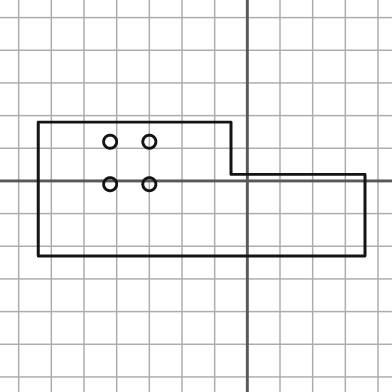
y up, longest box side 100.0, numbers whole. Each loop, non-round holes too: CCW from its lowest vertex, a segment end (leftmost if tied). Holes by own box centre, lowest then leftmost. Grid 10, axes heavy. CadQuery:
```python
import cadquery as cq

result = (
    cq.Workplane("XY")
    .moveTo(-64.0, -23.0)
    .lineTo(36.0, -23.0)
    .lineTo(36.0, 2.0)
    .lineTo(-5.0, 2.0)
    .lineTo(-5.0, 18.0)
    .lineTo(-64.0, 18.0)
    .close()
    .moveTo(-42.0, -1.0)
    .circle(2.0)
    .moveTo(-30.0, -1.0)
    .circle(2.0)
    .moveTo(-42.0, 12.0)
    .circle(2.0)
    .moveTo(-30.0, 12.0)
    .circle(2.0)
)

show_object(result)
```